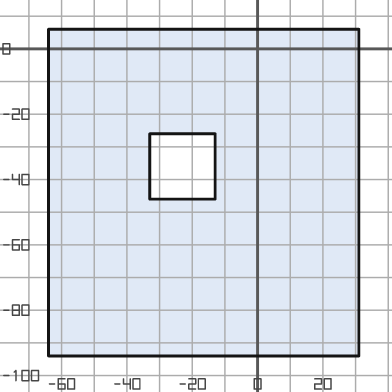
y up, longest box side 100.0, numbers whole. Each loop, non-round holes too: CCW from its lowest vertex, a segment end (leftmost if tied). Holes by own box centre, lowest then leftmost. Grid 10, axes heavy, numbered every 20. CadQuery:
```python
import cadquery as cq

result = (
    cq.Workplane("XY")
    .moveTo(-64.0, -94.0)
    .lineTo(31.0, -94.0)
    .lineTo(31.0, 6.0)
    .lineTo(-64.0, 6.0)
    .close()
    .moveTo(-33.0, -46.0)
    .lineTo(-13.0, -46.0)
    .lineTo(-13.0, -26.0)
    .lineTo(-33.0, -26.0)
    .close()
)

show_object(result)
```